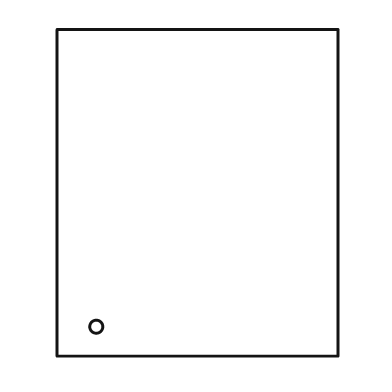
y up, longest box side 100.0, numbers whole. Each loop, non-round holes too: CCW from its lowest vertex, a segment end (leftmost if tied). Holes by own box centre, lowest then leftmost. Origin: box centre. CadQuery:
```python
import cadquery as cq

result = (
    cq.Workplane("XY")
    .moveTo(-43.0, -50.0)
    .lineTo(43.0, -50.0)
    .lineTo(43.0, 50.0)
    .lineTo(-43.0, 50.0)
    .close()
    .moveTo(-31.0, -41.0)
    .circle(2.0)
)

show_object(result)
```